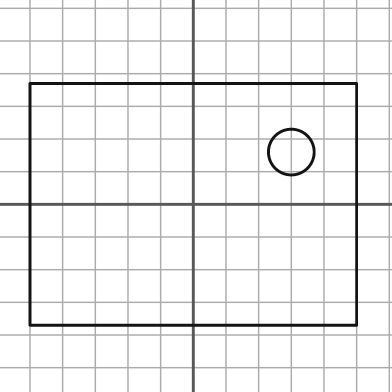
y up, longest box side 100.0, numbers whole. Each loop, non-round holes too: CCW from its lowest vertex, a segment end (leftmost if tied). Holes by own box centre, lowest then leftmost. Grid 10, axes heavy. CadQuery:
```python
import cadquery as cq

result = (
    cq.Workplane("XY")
    .moveTo(-50.0, -37.0)
    .lineTo(50.0, -37.0)
    .lineTo(50.0, 37.0)
    .lineTo(-50.0, 37.0)
    .close()
    .moveTo(30.0, 16.0)
    .circle(7.0)
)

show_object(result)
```